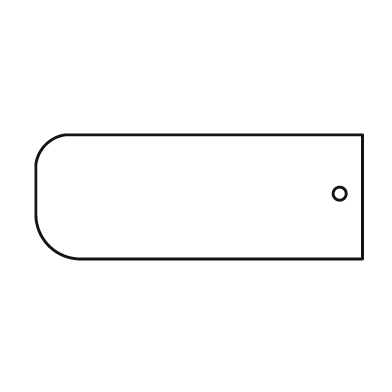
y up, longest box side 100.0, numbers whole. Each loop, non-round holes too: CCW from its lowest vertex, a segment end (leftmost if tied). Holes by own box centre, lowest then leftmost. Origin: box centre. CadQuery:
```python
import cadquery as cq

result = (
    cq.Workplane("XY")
    .moveTo(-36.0, -19.0)
    .lineTo(50.0, -19.0)
    .lineTo(50.0, 19.0)
    .lineTo(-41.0, 19.0)
    .threePointArc((-47.0, 16.0), (-50.0, 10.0))
    .lineTo(-50.0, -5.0)
    .threePointArc((-46.0, -15.0), (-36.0, -19.0))
    .close()
    .moveTo(43.0, 1.0)
    .circle(2.0)
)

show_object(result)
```